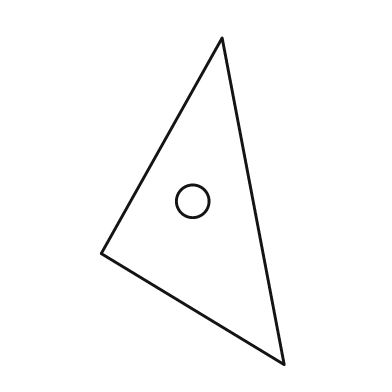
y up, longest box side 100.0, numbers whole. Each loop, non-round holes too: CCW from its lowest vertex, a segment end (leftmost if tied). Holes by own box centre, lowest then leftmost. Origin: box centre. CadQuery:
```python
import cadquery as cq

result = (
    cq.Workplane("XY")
    .moveTo(28.0, -50.0)
    .lineTo(9.0, 50.0)
    .lineTo(-28.0, -16.0)
    .close()
    .moveTo(0.0, 0.0)
    .circle(5.0)
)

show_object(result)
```